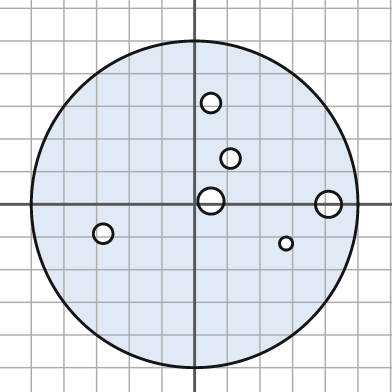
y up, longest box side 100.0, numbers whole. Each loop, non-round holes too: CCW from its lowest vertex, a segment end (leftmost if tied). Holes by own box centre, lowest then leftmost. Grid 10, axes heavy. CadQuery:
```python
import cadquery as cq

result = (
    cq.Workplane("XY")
    .moveTo(0.0, 0.0)
    .circle(50.0)
    .moveTo(28.0, -12.0)
    .circle(2.0)
    .moveTo(-28.0, -9.0)
    .circle(3.0)
    .moveTo(41.0, 0.0)
    .circle(4.0)
    .moveTo(5.0, 1.0)
    .circle(4.0)
    .moveTo(11.0, 14.0)
    .circle(3.0)
    .moveTo(5.0, 31.0)
    .circle(3.0)
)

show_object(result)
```